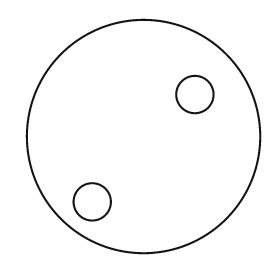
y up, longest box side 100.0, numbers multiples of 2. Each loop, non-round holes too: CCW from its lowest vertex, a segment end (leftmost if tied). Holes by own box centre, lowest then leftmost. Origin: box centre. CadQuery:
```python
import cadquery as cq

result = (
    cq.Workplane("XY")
    .moveTo(0.0, 0.0)
    .circle(50.0)
    .moveTo(-22.0, -28.0)
    .circle(8.0)
    .moveTo(22.0, 18.0)
    .circle(8.0)
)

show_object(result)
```